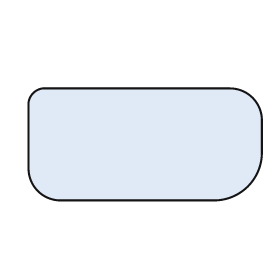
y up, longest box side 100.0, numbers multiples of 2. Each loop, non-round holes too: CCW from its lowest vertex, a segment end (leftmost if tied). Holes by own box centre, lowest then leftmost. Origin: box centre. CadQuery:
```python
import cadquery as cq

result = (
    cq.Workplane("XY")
    .moveTo(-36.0, -24.0)
    .lineTo(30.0, -24.0)
    .threePointArc((44.0, -18.0), (50.0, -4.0))
    .lineTo(50.0, 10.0)
    .threePointArc((46.0, 20.0), (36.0, 24.0))
    .lineTo(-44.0, 24.0)
    .threePointArc((-48.0, 22.0), (-50.0, 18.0))
    .lineTo(-50.0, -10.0)
    .threePointArc((-46.0, -20.0), (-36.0, -24.0))
    .close()
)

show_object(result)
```